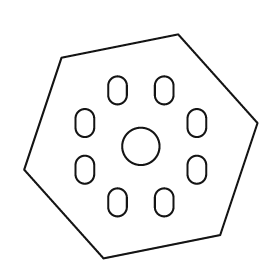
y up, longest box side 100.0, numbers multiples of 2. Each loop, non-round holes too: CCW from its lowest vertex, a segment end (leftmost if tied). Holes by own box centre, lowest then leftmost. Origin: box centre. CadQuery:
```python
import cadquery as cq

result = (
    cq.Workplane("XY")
    .moveTo(-16.0, -48.0)
    .lineTo(34.0, -38.0)
    .lineTo(50.0, 10.0)
    .lineTo(16.0, 48.0)
    .lineTo(-34.0, 38.0)
    .lineTo(-50.0, -10.0)
    .close()
    .moveTo(-14.0, -26.0)
    .threePointArc((-10.0, -30.0), (-6.0, -26.0))
    .lineTo(-6.0, -22.0)
    .threePointArc((-10.0, -18.0), (-14.0, -22.0))
    .close()
    .moveTo(6.0, -26.0)
    .threePointArc((10.0, -30.0), (14.0, -26.0))
    .lineTo(14.0, -22.0)
    .threePointArc((10.0, -18.0), (6.0, -22.0))
    .close()
    .moveTo(-28.0, -12.0)
    .threePointArc((-24.0, -16.0), (-20.0, -12.0))
    .lineTo(-20.0, -8.0)
    .threePointArc((-24.0, -4.0), (-28.0, -8.0))
    .close()
    .moveTo(20.0, -12.0)
    .threePointArc((24.0, -16.0), (28.0, -12.0))
    .lineTo(28.0, -8.0)
    .threePointArc((24.0, -4.0), (20.0, -8.0))
    .close()
    .moveTo(0.0, 0.0)
    .circle(8.0)
    .moveTo(-28.0, 8.0)
    .threePointArc((-24.0, 4.0), (-20.0, 8.0))
    .lineTo(-20.0, 12.0)
    .threePointArc((-24.0, 16.0), (-28.0, 12.0))
    .close()
    .moveTo(20.0, 8.0)
    .threePointArc((24.0, 4.0), (28.0, 8.0))
    .lineTo(28.0, 12.0)
    .threePointArc((24.0, 16.0), (20.0, 12.0))
    .close()
    .moveTo(-14.0, 22.0)
    .threePointArc((-10.0, 18.0), (-6.0, 22.0))
    .lineTo(-6.0, 26.0)
    .threePointArc((-10.0, 30.0), (-14.0, 26.0))
    .close()
    .moveTo(6.0, 22.0)
    .threePointArc((10.0, 18.0), (14.0, 22.0))
    .lineTo(14.0, 26.0)
    .threePointArc((10.0, 30.0), (6.0, 26.0))
    .close()
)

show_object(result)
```